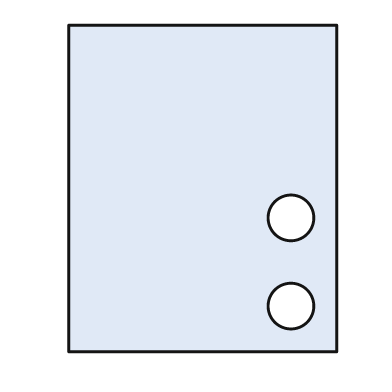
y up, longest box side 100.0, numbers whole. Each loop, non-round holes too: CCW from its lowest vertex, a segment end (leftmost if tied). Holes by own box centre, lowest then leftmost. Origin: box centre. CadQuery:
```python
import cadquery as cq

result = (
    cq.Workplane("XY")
    .moveTo(-41.0, -50.0)
    .lineTo(41.0, -50.0)
    .lineTo(41.0, 50.0)
    .lineTo(-41.0, 50.0)
    .close()
    .moveTo(27.0, -36.0)
    .circle(7.0)
    .moveTo(27.0, -9.0)
    .circle(7.0)
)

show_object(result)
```